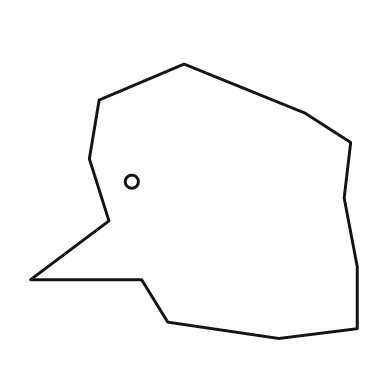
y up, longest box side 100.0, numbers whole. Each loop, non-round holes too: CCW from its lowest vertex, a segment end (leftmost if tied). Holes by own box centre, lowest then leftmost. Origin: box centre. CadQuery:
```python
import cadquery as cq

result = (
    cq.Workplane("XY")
    .moveTo(26.0, -42.0)
    .lineTo(50.0, -39.0)
    .lineTo(50.0, -20.0)
    .lineTo(46.0, 1.0)
    .lineTo(48.0, 18.0)
    .lineTo(34.0, 27.0)
    .lineTo(-3.0, 42.0)
    .lineTo(-29.0, 31.0)
    .lineTo(-32.0, 13.0)
    .lineTo(-26.0, -6.0)
    .lineTo(-50.0, -24.0)
    .lineTo(-16.0, -24.0)
    .lineTo(-8.0, -37.0)
    .close()
    .moveTo(-19.0, 6.0)
    .circle(2.0)
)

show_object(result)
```